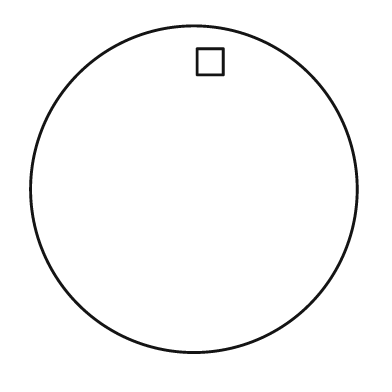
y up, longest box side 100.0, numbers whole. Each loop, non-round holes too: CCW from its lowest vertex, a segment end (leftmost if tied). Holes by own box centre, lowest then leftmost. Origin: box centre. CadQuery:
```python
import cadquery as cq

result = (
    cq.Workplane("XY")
    .moveTo(0.0, 0.0)
    .circle(50.0)
    .moveTo(1.0, 35.0)
    .lineTo(9.0, 35.0)
    .lineTo(9.0, 43.0)
    .lineTo(1.0, 43.0)
    .close()
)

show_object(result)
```